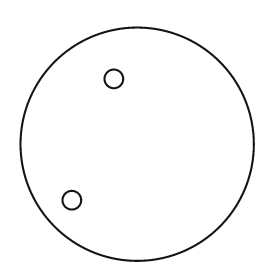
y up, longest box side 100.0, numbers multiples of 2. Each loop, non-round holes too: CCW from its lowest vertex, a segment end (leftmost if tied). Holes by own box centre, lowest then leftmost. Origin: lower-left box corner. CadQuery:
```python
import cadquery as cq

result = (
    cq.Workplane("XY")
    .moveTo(50.0, 50.0)
    .circle(50.0)
    .moveTo(22.0, 26.0)
    .circle(4.0)
    .moveTo(40.0, 78.0)
    .circle(4.0)
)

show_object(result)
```